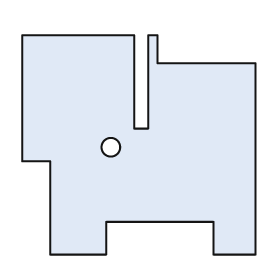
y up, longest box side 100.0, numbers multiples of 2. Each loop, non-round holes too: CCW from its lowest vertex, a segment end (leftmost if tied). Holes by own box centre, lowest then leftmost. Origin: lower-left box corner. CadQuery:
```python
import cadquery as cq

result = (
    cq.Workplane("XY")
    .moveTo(12.0, 0.0)
    .lineTo(36.0, 0.0)
    .lineTo(36.0, 14.0)
    .lineTo(82.0, 14.0)
    .lineTo(82.0, 0.0)
    .lineTo(100.0, 0.0)
    .lineTo(100.0, 82.0)
    .lineTo(58.0, 82.0)
    .lineTo(58.0, 94.0)
    .lineTo(54.0, 94.0)
    .lineTo(54.0, 54.0)
    .lineTo(48.0, 54.0)
    .lineTo(48.0, 94.0)
    .lineTo(0.0, 94.0)
    .lineTo(0.0, 40.0)
    .lineTo(12.0, 40.0)
    .close()
    .moveTo(38.0, 46.0)
    .circle(4.0)
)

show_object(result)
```